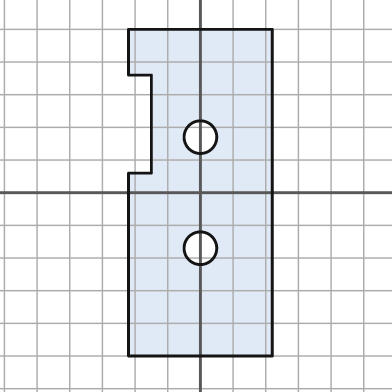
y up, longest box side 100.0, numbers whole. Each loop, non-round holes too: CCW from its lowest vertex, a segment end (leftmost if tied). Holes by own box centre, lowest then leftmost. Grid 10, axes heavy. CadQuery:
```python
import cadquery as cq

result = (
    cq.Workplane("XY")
    .moveTo(-22.0, -50.0)
    .lineTo(22.0, -50.0)
    .lineTo(22.0, 50.0)
    .lineTo(-22.0, 50.0)
    .lineTo(-22.0, 36.0)
    .lineTo(-15.0, 36.0)
    .lineTo(-15.0, 6.0)
    .lineTo(-22.0, 6.0)
    .close()
    .moveTo(0.0, -17.0)
    .circle(5.0)
    .moveTo(0.0, 17.0)
    .circle(5.0)
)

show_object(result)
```